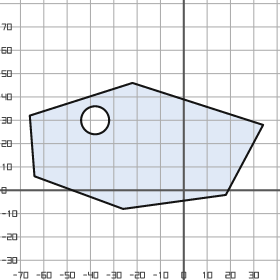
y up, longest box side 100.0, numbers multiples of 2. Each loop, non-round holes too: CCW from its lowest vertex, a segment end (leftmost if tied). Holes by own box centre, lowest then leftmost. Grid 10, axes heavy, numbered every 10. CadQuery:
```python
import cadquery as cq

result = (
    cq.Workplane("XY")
    .moveTo(-26.0, -8.0)
    .lineTo(18.0, -2.0)
    .lineTo(34.0, 28.0)
    .lineTo(-22.0, 46.0)
    .lineTo(-66.0, 32.0)
    .lineTo(-64.0, 6.0)
    .close()
    .moveTo(-38.0, 30.0)
    .circle(6.0)
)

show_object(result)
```